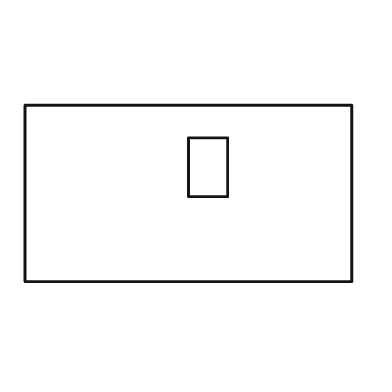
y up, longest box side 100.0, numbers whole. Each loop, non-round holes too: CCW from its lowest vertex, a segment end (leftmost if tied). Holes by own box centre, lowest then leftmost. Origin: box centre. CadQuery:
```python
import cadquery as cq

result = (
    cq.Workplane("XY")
    .moveTo(-50.0, -27.0)
    .lineTo(50.0, -27.0)
    .lineTo(50.0, 27.0)
    .lineTo(-50.0, 27.0)
    .close()
    .moveTo(0.0, -1.0)
    .lineTo(12.0, -1.0)
    .lineTo(12.0, 17.0)
    .lineTo(0.0, 17.0)
    .close()
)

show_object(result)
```